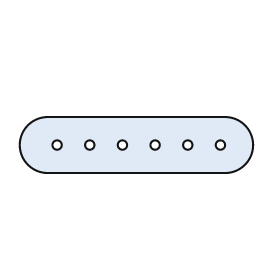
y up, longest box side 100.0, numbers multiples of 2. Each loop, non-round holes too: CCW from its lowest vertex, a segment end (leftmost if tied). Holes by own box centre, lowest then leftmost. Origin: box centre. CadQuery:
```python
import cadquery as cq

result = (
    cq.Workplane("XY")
    .moveTo(-38.0, -12.0)
    .lineTo(38.0, -12.0)
    .threePointArc((50.0, 0.0), (38.0, 12.0))
    .lineTo(-38.0, 12.0)
    .threePointArc((-50.0, 0.0), (-38.0, -12.0))
    .close()
    .moveTo(-34.0, 0.0)
    .circle(2.0)
    .moveTo(-20.0, 0.0)
    .circle(2.0)
    .moveTo(-6.0, 0.0)
    .circle(2.0)
    .moveTo(8.0, 0.0)
    .circle(2.0)
    .moveTo(22.0, 0.0)
    .circle(2.0)
    .moveTo(36.0, 0.0)
    .circle(2.0)
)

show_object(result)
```